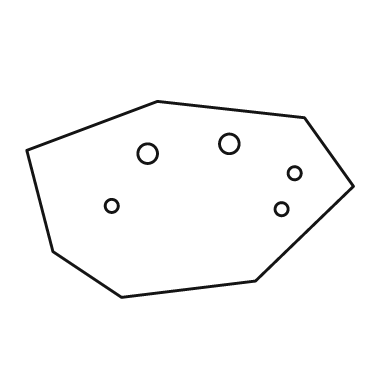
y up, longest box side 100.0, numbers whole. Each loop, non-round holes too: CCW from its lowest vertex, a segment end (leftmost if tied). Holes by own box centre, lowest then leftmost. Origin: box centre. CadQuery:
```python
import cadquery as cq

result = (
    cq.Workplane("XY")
    .moveTo(-21.0, -30.0)
    .lineTo(20.0, -25.0)
    .lineTo(50.0, 4.0)
    .lineTo(35.0, 25.0)
    .lineTo(-10.0, 30.0)
    .lineTo(-50.0, 15.0)
    .lineTo(-42.0, -16.0)
    .close()
    .moveTo(28.0, -3.0)
    .circle(2.0)
    .moveTo(-24.0, -2.0)
    .circle(2.0)
    .moveTo(32.0, 8.0)
    .circle(2.0)
    .moveTo(-13.0, 14.0)
    .circle(3.0)
    .moveTo(12.0, 17.0)
    .circle(3.0)
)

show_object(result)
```